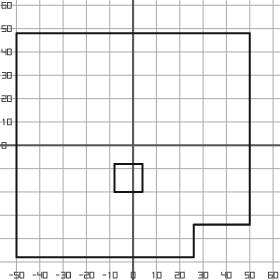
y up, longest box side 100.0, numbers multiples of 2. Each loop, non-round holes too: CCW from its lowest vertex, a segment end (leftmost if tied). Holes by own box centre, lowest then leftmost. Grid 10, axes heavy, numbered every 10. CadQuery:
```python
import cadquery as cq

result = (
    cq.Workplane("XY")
    .moveTo(-50.0, -48.0)
    .lineTo(26.0, -48.0)
    .lineTo(26.0, -34.0)
    .lineTo(50.0, -34.0)
    .lineTo(50.0, 48.0)
    .lineTo(-50.0, 48.0)
    .close()
    .moveTo(-8.0, -20.0)
    .lineTo(4.0, -20.0)
    .lineTo(4.0, -8.0)
    .lineTo(-8.0, -8.0)
    .close()
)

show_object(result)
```